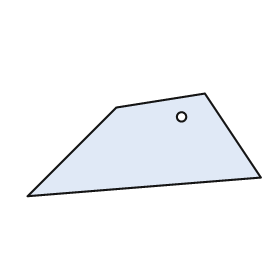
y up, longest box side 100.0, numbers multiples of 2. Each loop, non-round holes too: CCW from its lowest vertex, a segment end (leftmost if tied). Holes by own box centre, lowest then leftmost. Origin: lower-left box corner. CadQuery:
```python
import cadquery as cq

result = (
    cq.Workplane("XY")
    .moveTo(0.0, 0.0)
    .lineTo(100.0, 8.0)
    .lineTo(76.0, 44.0)
    .lineTo(38.0, 38.0)
    .close()
    .moveTo(66.0, 34.0)
    .circle(2.0)
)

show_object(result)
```